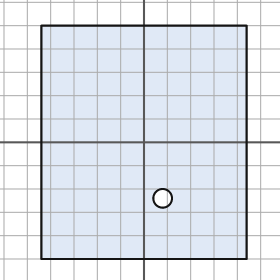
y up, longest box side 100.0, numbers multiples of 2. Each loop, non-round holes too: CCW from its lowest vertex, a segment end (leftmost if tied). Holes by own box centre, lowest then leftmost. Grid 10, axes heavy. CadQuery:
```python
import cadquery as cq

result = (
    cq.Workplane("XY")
    .moveTo(-44.0, -50.0)
    .lineTo(44.0, -50.0)
    .lineTo(44.0, 50.0)
    .lineTo(-44.0, 50.0)
    .close()
    .moveTo(8.0, -24.0)
    .circle(4.0)
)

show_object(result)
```